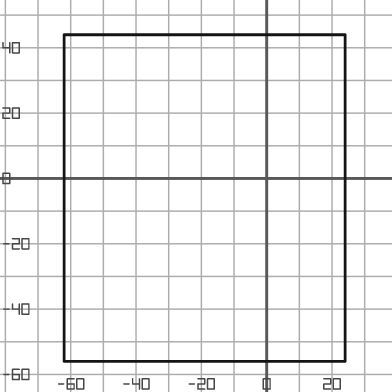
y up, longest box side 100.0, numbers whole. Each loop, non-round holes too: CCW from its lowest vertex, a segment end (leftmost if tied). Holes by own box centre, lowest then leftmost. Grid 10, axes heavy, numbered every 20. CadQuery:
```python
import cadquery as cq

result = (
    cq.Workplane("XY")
    .moveTo(-62.0, -56.0)
    .lineTo(24.0, -56.0)
    .lineTo(24.0, 44.0)
    .lineTo(-62.0, 44.0)
    .close()
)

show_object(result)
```